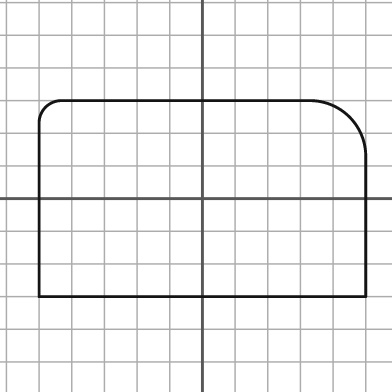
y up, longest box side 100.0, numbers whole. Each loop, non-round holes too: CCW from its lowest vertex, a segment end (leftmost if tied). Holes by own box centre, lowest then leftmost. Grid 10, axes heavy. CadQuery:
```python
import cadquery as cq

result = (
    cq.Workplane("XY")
    .moveTo(-50.0, -30.0)
    .lineTo(50.0, -30.0)
    .lineTo(50.0, 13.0)
    .threePointArc((45.0, 25.0), (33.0, 30.0))
    .lineTo(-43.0, 30.0)
    .threePointArc((-48.0, 28.0), (-50.0, 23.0))
    .close()
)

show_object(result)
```